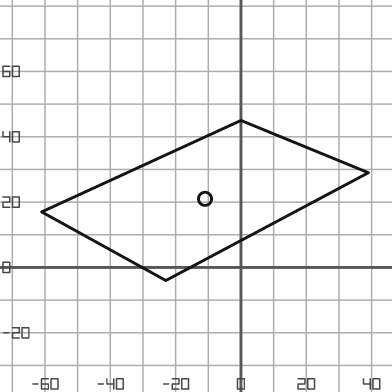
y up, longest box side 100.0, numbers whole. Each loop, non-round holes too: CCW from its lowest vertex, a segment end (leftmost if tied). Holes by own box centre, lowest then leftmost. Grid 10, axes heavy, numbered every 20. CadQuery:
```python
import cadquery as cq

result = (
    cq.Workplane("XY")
    .moveTo(-23.0, -4.0)
    .lineTo(39.0, 29.0)
    .lineTo(0.0, 45.0)
    .lineTo(-61.0, 17.0)
    .close()
    .moveTo(-11.0, 21.0)
    .circle(2.0)
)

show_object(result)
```